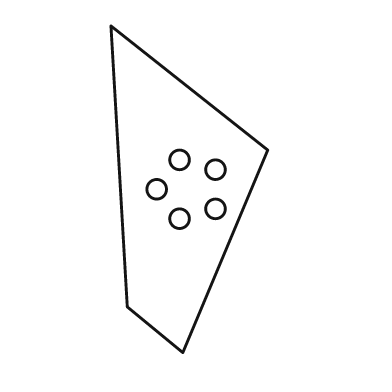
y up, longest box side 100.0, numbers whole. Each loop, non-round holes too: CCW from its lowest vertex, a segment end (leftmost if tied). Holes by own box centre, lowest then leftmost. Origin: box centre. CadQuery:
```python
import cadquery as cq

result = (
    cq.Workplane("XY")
    .moveTo(-2.0, -50.0)
    .lineTo(24.0, 12.0)
    .lineTo(-24.0, 50.0)
    .lineTo(-19.0, -36.0)
    .close()
    .moveTo(-3.0, -9.0)
    .circle(3.0)
    .moveTo(8.0, -6.0)
    .circle(3.0)
    .moveTo(-10.0, 0.0)
    .circle(3.0)
    .moveTo(8.0, 6.0)
    .circle(3.0)
    .moveTo(-3.0, 9.0)
    .circle(3.0)
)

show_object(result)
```